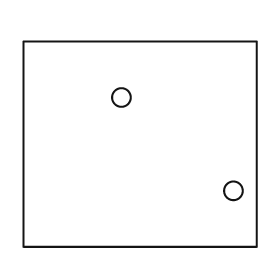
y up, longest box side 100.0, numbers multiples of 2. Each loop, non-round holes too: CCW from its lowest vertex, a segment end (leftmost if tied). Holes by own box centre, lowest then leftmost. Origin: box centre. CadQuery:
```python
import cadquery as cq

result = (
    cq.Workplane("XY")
    .moveTo(-50.0, -44.0)
    .lineTo(50.0, -44.0)
    .lineTo(50.0, 44.0)
    .lineTo(-50.0, 44.0)
    .close()
    .moveTo(40.0, -20.0)
    .circle(4.0)
    .moveTo(-8.0, 20.0)
    .circle(4.0)
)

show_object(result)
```